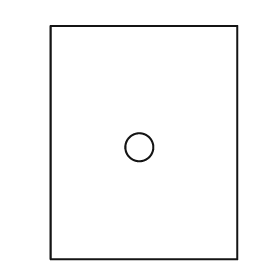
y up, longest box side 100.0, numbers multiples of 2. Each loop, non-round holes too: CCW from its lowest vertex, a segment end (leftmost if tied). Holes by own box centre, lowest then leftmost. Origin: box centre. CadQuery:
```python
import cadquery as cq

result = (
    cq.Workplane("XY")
    .moveTo(-40.0, -50.0)
    .lineTo(40.0, -50.0)
    .lineTo(40.0, 50.0)
    .lineTo(-40.0, 50.0)
    .close()
    .moveTo(-2.0, -2.0)
    .circle(6.0)
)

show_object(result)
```